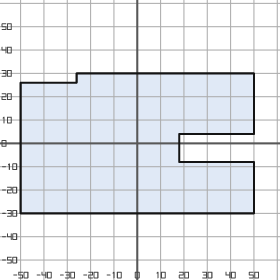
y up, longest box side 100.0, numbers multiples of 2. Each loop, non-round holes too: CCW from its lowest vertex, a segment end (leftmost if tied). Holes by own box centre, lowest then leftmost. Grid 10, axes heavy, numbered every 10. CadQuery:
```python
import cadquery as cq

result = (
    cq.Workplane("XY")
    .moveTo(-50.0, -30.0)
    .lineTo(50.0, -30.0)
    .lineTo(50.0, -8.0)
    .lineTo(18.0, -8.0)
    .lineTo(18.0, 4.0)
    .lineTo(50.0, 4.0)
    .lineTo(50.0, 30.0)
    .lineTo(-26.0, 30.0)
    .lineTo(-26.0, 26.0)
    .lineTo(-50.0, 26.0)
    .close()
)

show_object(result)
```